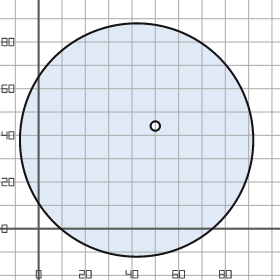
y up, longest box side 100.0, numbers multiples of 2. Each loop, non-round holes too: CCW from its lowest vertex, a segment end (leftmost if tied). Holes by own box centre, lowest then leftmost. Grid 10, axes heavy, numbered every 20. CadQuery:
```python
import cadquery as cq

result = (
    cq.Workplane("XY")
    .moveTo(42.0, 38.0)
    .circle(50.0)
    .moveTo(50.0, 44.0)
    .circle(2.0)
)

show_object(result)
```